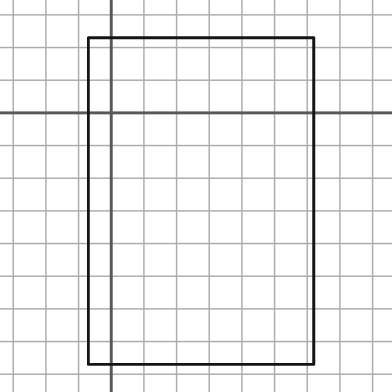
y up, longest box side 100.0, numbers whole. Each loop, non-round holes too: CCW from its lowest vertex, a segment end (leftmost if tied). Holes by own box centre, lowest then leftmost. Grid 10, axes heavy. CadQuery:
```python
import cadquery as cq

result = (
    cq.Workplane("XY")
    .moveTo(-7.0, -77.0)
    .lineTo(62.0, -77.0)
    .lineTo(62.0, 23.0)
    .lineTo(-7.0, 23.0)
    .close()
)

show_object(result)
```